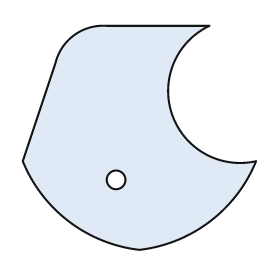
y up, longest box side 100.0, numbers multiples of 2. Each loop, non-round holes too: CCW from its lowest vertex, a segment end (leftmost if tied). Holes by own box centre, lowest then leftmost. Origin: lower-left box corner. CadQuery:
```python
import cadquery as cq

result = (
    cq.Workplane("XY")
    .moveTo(50.0, 0.0)
    .threePointArc((80.0, 12.0), (100.0, 38.0))
    .threePointArc((64.0, 58.0), (80.0, 96.0))
    .lineTo(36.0, 96.0)
    .threePointArc((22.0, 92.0), (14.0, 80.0))
    .lineTo(0.0, 38.0)
    .threePointArc((20.0, 12.0), (50.0, 0.0))
    .close()
    .moveTo(40.0, 30.0)
    .circle(4.0)
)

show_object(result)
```